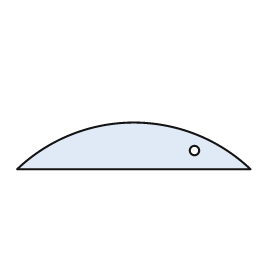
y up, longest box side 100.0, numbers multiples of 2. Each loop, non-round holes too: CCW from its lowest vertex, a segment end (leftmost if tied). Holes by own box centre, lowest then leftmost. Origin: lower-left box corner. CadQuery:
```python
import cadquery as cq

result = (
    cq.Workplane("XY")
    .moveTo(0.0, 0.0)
    .lineTo(100.0, 0.0)
    .threePointArc((50.0, 20.0), (0.0, 0.0))
    .close()
    .moveTo(76.0, 8.0)
    .circle(2.0)
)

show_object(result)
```